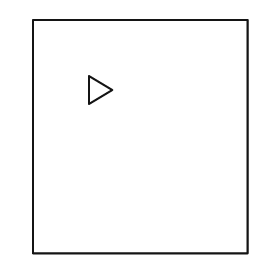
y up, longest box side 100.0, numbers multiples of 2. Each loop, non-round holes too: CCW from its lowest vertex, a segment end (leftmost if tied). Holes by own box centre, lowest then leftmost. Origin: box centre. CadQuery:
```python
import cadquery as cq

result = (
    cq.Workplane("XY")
    .moveTo(-46.0, -50.0)
    .lineTo(46.0, -50.0)
    .lineTo(46.0, 50.0)
    .lineTo(-46.0, 50.0)
    .close()
    .moveTo(-22.0, 14.0)
    .lineTo(-12.0, 20.0)
    .lineTo(-22.0, 26.0)
    .close()
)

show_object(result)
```